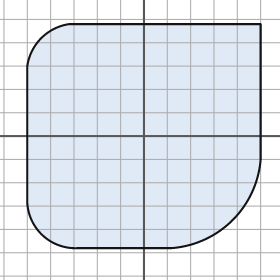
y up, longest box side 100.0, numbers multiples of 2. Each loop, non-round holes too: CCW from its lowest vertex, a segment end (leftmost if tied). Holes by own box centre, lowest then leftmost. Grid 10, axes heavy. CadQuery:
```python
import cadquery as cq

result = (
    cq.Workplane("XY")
    .moveTo(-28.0, -48.0)
    .lineTo(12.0, -48.0)
    .threePointArc((38.0, -36.0), (50.0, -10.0))
    .lineTo(50.0, 48.0)
    .lineTo(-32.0, 48.0)
    .threePointArc((-44.0, 42.0), (-50.0, 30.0))
    .lineTo(-50.0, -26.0)
    .threePointArc((-44.0, -42.0), (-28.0, -48.0))
    .close()
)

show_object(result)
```